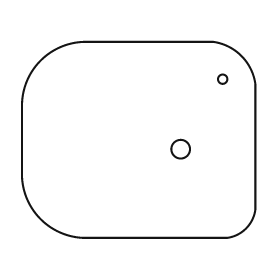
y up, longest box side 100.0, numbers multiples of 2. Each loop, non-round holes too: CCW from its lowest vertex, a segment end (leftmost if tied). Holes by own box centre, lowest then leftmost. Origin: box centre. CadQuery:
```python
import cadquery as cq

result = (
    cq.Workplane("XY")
    .moveTo(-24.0, -42.0)
    .lineTo(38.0, -42.0)
    .threePointArc((46.0, -38.0), (50.0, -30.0))
    .lineTo(50.0, 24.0)
    .threePointArc((44.0, 36.0), (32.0, 42.0))
    .lineTo(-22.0, 42.0)
    .threePointArc((-42.0, 34.0), (-50.0, 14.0))
    .lineTo(-50.0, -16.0)
    .threePointArc((-42.0, -34.0), (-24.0, -42.0))
    .close()
    .moveTo(18.0, -4.0)
    .circle(4.0)
    .moveTo(36.0, 26.0)
    .circle(2.0)
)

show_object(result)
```